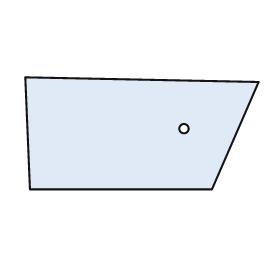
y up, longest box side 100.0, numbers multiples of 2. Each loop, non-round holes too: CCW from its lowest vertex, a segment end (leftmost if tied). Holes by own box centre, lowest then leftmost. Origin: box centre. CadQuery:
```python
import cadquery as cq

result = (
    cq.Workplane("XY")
    .moveTo(-48.0, -24.0)
    .lineTo(30.0, -24.0)
    .lineTo(50.0, 22.0)
    .lineTo(-50.0, 24.0)
    .close()
    .moveTo(18.0, 2.0)
    .circle(2.0)
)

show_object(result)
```